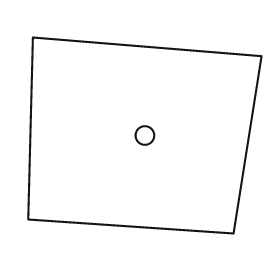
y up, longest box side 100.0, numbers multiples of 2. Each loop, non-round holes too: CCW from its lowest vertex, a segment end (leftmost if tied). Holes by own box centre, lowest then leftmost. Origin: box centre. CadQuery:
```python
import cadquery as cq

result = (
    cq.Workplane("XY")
    .moveTo(38.0, -42.0)
    .lineTo(50.0, 34.0)
    .lineTo(-48.0, 42.0)
    .lineTo(-50.0, -36.0)
    .close()
    .moveTo(0.0, 0.0)
    .circle(4.0)
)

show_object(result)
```